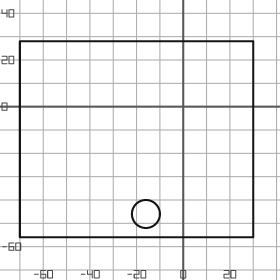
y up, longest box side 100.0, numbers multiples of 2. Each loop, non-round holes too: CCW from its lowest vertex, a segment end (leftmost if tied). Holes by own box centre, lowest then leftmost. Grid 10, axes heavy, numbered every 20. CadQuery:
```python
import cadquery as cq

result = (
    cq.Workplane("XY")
    .moveTo(-70.0, -56.0)
    .lineTo(30.0, -56.0)
    .lineTo(30.0, 28.0)
    .lineTo(-70.0, 28.0)
    .close()
    .moveTo(-16.0, -46.0)
    .circle(6.0)
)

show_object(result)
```